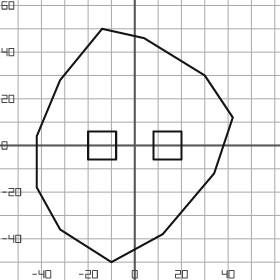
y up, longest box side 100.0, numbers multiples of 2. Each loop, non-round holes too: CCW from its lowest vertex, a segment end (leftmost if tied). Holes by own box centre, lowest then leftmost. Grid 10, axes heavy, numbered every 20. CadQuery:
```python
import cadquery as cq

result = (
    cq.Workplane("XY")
    .moveTo(-10.0, -50.0)
    .lineTo(12.0, -38.0)
    .lineTo(34.0, -12.0)
    .lineTo(42.0, 12.0)
    .lineTo(30.0, 30.0)
    .lineTo(4.0, 46.0)
    .lineTo(-14.0, 50.0)
    .lineTo(-32.0, 28.0)
    .lineTo(-42.0, 4.0)
    .lineTo(-42.0, -18.0)
    .lineTo(-32.0, -36.0)
    .close()
    .moveTo(-20.0, -6.0)
    .lineTo(-8.0, -6.0)
    .lineTo(-8.0, 6.0)
    .lineTo(-20.0, 6.0)
    .close()
    .moveTo(8.0, -6.0)
    .lineTo(20.0, -6.0)
    .lineTo(20.0, 6.0)
    .lineTo(8.0, 6.0)
    .close()
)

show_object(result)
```